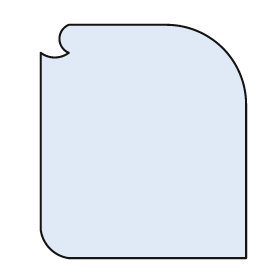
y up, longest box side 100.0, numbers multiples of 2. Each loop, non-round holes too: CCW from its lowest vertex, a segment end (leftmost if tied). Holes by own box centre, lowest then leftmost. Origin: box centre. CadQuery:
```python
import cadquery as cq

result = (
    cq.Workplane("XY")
    .moveTo(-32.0, -50.0)
    .lineTo(44.0, -50.0)
    .lineTo(44.0, 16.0)
    .threePointArc((34.0, 40.0), (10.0, 50.0))
    .lineTo(-32.0, 50.0)
    .threePointArc((-36.0, 44.0), (-32.0, 38.0))
    .threePointArc((-38.0, 36.0), (-44.0, 38.0))
    .lineTo(-44.0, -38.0)
    .threePointArc((-40.0, -46.0), (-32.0, -50.0))
    .close()
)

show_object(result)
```